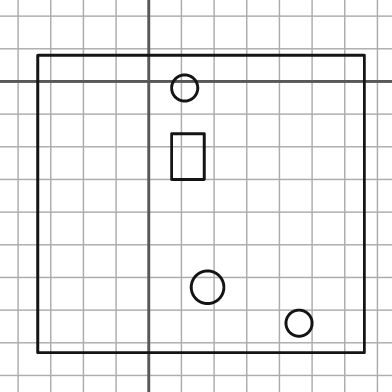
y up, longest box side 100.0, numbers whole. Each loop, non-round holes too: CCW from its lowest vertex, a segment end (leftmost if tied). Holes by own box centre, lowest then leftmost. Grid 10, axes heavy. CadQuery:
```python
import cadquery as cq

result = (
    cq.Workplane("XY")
    .moveTo(-34.0, -83.0)
    .lineTo(66.0, -83.0)
    .lineTo(66.0, 8.0)
    .lineTo(-34.0, 8.0)
    .close()
    .moveTo(46.0, -74.0)
    .circle(4.0)
    .moveTo(18.0, -63.0)
    .circle(5.0)
    .moveTo(7.0, -30.0)
    .lineTo(17.0, -30.0)
    .lineTo(17.0, -16.0)
    .lineTo(7.0, -16.0)
    .close()
    .moveTo(11.0, -2.0)
    .circle(4.0)
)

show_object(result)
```